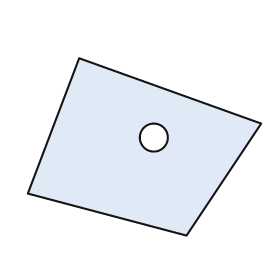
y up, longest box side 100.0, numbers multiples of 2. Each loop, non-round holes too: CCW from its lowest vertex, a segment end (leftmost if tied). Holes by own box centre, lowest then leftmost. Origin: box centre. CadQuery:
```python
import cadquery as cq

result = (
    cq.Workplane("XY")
    .moveTo(18.0, -38.0)
    .lineTo(50.0, 10.0)
    .lineTo(-28.0, 38.0)
    .lineTo(-50.0, -20.0)
    .close()
    .moveTo(4.0, 4.0)
    .circle(6.0)
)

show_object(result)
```